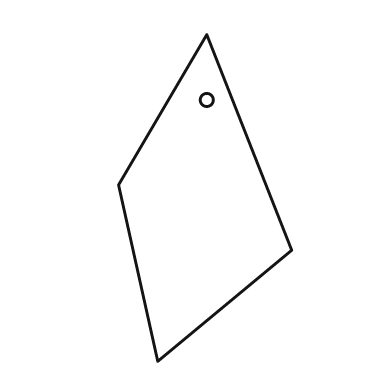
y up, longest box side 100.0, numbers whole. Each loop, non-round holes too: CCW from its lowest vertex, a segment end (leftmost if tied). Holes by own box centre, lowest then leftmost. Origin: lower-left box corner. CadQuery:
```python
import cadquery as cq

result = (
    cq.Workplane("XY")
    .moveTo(12.0, 0.0)
    .lineTo(53.0, 34.0)
    .lineTo(27.0, 100.0)
    .lineTo(0.0, 54.0)
    .close()
    .moveTo(27.0, 80.0)
    .circle(2.0)
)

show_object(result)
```